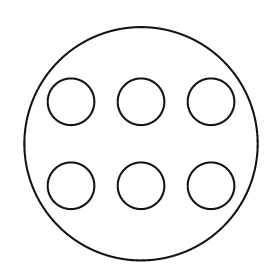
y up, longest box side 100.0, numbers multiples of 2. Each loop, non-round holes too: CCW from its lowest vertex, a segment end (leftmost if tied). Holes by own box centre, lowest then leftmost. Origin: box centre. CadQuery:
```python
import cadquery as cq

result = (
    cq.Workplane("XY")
    .moveTo(0.0, 0.0)
    .circle(50.0)
    .moveTo(-30.0, -18.0)
    .circle(10.0)
    .moveTo(0.0, -18.0)
    .circle(10.0)
    .moveTo(30.0, -18.0)
    .circle(10.0)
    .moveTo(-30.0, 18.0)
    .circle(10.0)
    .moveTo(0.0, 18.0)
    .circle(10.0)
    .moveTo(30.0, 18.0)
    .circle(10.0)
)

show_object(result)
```